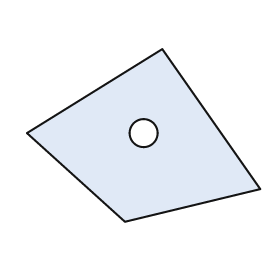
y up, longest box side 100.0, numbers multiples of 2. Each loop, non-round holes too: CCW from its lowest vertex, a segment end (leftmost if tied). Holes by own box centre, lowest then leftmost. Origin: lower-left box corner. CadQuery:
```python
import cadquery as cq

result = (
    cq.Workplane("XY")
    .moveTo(42.0, 0.0)
    .lineTo(100.0, 14.0)
    .lineTo(58.0, 74.0)
    .lineTo(0.0, 38.0)
    .close()
    .moveTo(50.0, 38.0)
    .circle(6.0)
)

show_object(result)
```